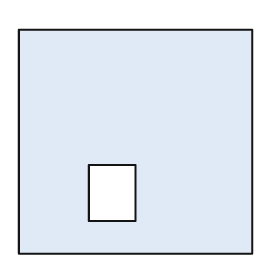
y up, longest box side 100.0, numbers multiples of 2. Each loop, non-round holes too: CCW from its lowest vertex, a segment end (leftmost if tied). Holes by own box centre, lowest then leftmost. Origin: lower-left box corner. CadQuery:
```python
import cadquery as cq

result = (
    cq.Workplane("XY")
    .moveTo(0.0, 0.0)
    .lineTo(100.0, 0.0)
    .lineTo(100.0, 96.0)
    .lineTo(0.0, 96.0)
    .close()
    .moveTo(30.0, 14.0)
    .lineTo(50.0, 14.0)
    .lineTo(50.0, 38.0)
    .lineTo(30.0, 38.0)
    .close()
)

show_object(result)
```